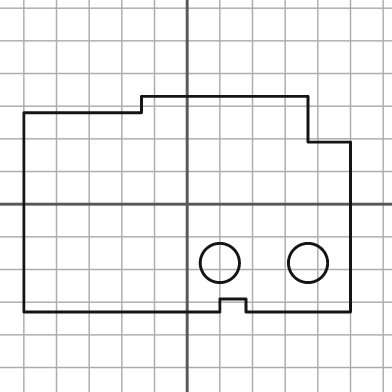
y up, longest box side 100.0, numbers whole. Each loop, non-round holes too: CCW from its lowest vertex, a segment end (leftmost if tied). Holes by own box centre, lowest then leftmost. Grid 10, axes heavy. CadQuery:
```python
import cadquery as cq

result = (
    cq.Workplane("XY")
    .moveTo(-50.0, -33.0)
    .lineTo(10.0, -33.0)
    .lineTo(10.0, -29.0)
    .lineTo(18.0, -29.0)
    .lineTo(18.0, -33.0)
    .lineTo(50.0, -33.0)
    .lineTo(50.0, 19.0)
    .lineTo(37.0, 19.0)
    .lineTo(37.0, 33.0)
    .lineTo(-14.0, 33.0)
    .lineTo(-14.0, 28.0)
    .lineTo(-50.0, 28.0)
    .close()
    .moveTo(10.0, -18.0)
    .circle(6.0)
    .moveTo(37.0, -18.0)
    .circle(6.0)
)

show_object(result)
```